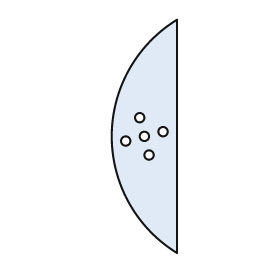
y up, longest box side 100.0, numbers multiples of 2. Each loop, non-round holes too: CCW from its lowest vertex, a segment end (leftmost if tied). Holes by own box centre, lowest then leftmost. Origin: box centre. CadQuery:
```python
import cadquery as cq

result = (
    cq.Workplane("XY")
    .moveTo(14.0, -50.0)
    .lineTo(14.0, 50.0)
    .threePointArc((-14.0, 0.0), (14.0, -50.0))
    .close()
    .moveTo(2.0, -8.0)
    .circle(2.0)
    .moveTo(-8.0, -2.0)
    .circle(2.0)
    .moveTo(0.0, 0.0)
    .circle(2.0)
    .moveTo(8.0, 2.0)
    .circle(2.0)
    .moveTo(-2.0, 8.0)
    .circle(2.0)
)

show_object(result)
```